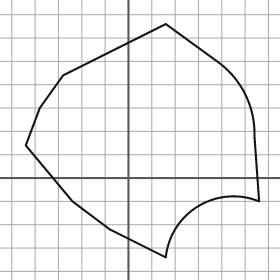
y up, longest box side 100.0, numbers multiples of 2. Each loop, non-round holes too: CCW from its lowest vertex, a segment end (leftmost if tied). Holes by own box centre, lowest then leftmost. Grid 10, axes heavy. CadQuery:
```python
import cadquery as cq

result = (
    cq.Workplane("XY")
    .moveTo(16.0, -34.0)
    .threePointArc((30.0, -12.0), (56.0, -10.0))
    .lineTo(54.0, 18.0)
    .threePointArc((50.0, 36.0), (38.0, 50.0))
    .lineTo(16.0, 66.0)
    .lineTo(-28.0, 44.0)
    .lineTo(-38.0, 30.0)
    .lineTo(-44.0, 14.0)
    .lineTo(-24.0, -10.0)
    .lineTo(-8.0, -22.0)
    .close()
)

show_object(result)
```